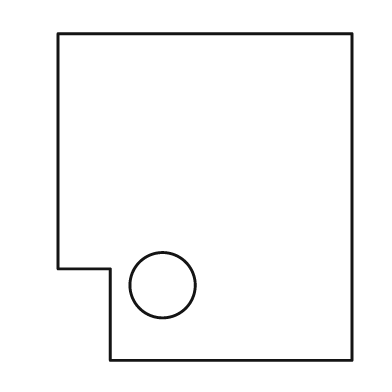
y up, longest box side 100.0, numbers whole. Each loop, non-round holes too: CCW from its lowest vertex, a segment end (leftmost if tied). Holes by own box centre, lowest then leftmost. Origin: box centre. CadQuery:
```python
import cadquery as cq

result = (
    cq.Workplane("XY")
    .moveTo(-29.0, -50.0)
    .lineTo(45.0, -50.0)
    .lineTo(45.0, 50.0)
    .lineTo(-45.0, 50.0)
    .lineTo(-45.0, -22.0)
    .lineTo(-29.0, -22.0)
    .close()
    .moveTo(-13.0, -27.0)
    .circle(10.0)
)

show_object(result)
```